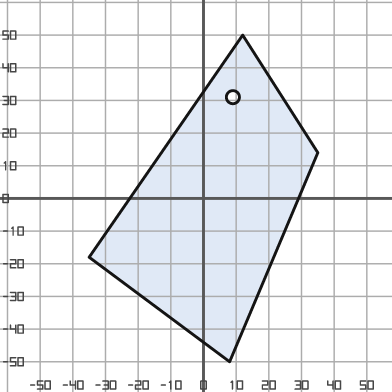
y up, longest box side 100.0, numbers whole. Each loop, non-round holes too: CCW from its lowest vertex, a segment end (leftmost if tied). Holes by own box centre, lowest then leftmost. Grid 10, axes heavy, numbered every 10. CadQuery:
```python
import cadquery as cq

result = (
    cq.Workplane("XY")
    .moveTo(8.0, -50.0)
    .lineTo(35.0, 14.0)
    .lineTo(12.0, 50.0)
    .lineTo(-35.0, -18.0)
    .close()
    .moveTo(9.0, 31.0)
    .circle(2.0)
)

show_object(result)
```